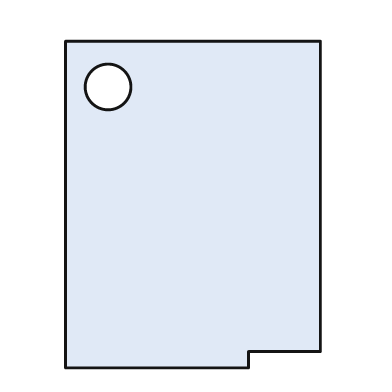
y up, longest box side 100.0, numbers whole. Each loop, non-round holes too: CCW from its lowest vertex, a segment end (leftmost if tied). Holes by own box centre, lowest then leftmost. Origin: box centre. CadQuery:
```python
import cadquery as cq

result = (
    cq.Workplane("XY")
    .moveTo(-39.0, -50.0)
    .lineTo(17.0, -50.0)
    .lineTo(17.0, -45.0)
    .lineTo(39.0, -45.0)
    .lineTo(39.0, 50.0)
    .lineTo(-39.0, 50.0)
    .close()
    .moveTo(-26.0, 36.0)
    .circle(7.0)
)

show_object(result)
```